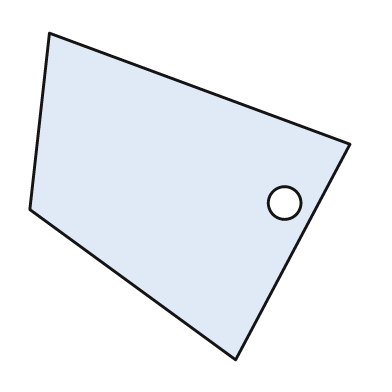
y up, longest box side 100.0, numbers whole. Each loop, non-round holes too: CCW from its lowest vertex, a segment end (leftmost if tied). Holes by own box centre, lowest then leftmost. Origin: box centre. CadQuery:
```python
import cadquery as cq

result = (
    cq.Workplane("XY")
    .moveTo(14.0, -50.0)
    .lineTo(49.0, 16.0)
    .lineTo(-43.0, 50.0)
    .lineTo(-49.0, -4.0)
    .close()
    .moveTo(29.0, -2.0)
    .circle(5.0)
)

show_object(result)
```